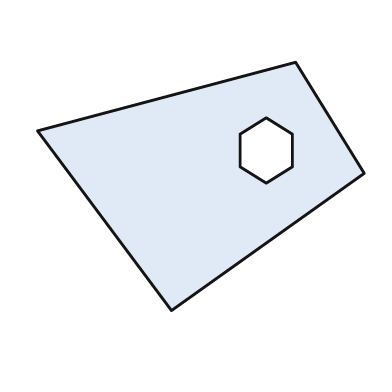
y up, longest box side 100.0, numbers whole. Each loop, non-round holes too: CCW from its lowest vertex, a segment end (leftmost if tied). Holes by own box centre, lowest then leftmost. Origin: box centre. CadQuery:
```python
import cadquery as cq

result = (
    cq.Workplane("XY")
    .moveTo(-9.0, -38.0)
    .lineTo(50.0, 4.0)
    .lineTo(29.0, 38.0)
    .lineTo(-50.0, 17.0)
    .close()
    .moveTo(20.0, 1.0)
    .lineTo(28.0, 6.0)
    .lineTo(28.0, 16.0)
    .lineTo(20.0, 21.0)
    .lineTo(12.0, 16.0)
    .lineTo(12.0, 6.0)
    .close()
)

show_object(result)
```